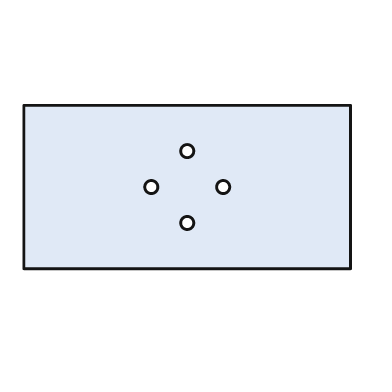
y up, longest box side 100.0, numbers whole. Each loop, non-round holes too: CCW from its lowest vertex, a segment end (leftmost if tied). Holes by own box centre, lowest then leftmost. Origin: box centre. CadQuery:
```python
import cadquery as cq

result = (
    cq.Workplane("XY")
    .moveTo(-50.0, -25.0)
    .lineTo(50.0, -25.0)
    .lineTo(50.0, 25.0)
    .lineTo(-50.0, 25.0)
    .close()
    .moveTo(0.0, -11.0)
    .circle(2.0)
    .moveTo(-11.0, 0.0)
    .circle(2.0)
    .moveTo(11.0, 0.0)
    .circle(2.0)
    .moveTo(0.0, 11.0)
    .circle(2.0)
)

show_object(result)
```